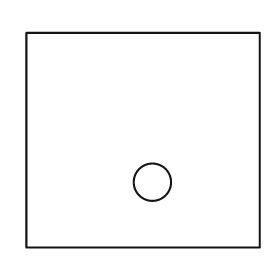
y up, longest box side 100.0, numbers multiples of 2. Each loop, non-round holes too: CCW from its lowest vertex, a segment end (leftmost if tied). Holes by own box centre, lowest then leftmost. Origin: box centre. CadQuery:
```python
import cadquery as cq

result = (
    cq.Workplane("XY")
    .moveTo(-50.0, -46.0)
    .lineTo(50.0, -46.0)
    .lineTo(50.0, 46.0)
    .lineTo(-50.0, 46.0)
    .close()
    .moveTo(4.0, -18.0)
    .circle(8.0)
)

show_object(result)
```